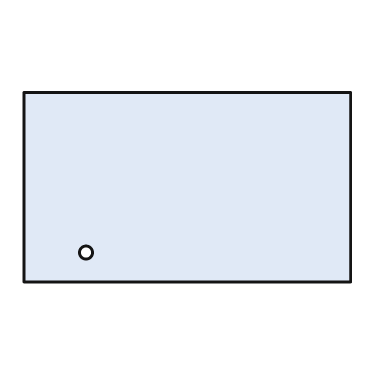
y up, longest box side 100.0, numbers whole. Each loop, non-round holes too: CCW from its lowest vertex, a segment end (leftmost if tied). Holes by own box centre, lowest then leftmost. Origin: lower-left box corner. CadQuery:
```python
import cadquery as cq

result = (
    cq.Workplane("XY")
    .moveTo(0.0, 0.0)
    .lineTo(100.0, 0.0)
    .lineTo(100.0, 58.0)
    .lineTo(0.0, 58.0)
    .close()
    .moveTo(19.0, 9.0)
    .circle(2.0)
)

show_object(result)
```